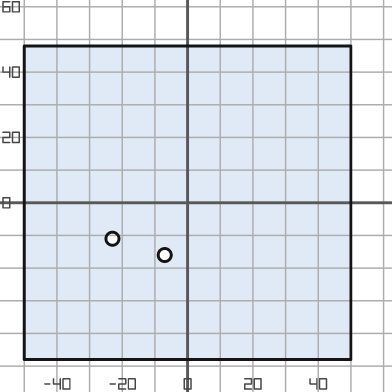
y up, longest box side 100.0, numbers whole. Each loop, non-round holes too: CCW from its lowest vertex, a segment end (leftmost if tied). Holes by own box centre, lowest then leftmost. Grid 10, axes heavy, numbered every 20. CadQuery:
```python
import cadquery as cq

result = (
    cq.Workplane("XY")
    .moveTo(-50.0, -48.0)
    .lineTo(50.0, -48.0)
    .lineTo(50.0, 48.0)
    .lineTo(-50.0, 48.0)
    .close()
    .moveTo(-7.0, -16.0)
    .circle(2.0)
    .moveTo(-23.0, -11.0)
    .circle(2.0)
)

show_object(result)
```